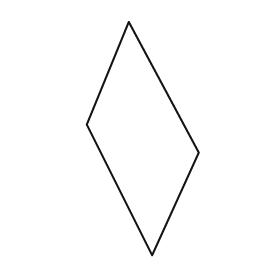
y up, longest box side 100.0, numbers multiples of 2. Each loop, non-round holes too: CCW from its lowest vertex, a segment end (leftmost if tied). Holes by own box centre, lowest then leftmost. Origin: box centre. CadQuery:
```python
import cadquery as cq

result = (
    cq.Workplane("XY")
    .moveTo(4.0, -50.0)
    .lineTo(24.0, -6.0)
    .lineTo(-6.0, 50.0)
    .lineTo(-24.0, 6.0)
    .close()
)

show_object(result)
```